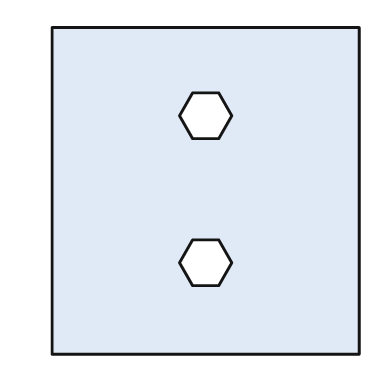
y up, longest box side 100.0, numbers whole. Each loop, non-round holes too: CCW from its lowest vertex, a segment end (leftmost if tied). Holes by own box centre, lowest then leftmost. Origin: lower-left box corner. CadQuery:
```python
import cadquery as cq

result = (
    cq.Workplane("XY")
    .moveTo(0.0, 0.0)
    .lineTo(94.0, 0.0)
    .lineTo(94.0, 100.0)
    .lineTo(0.0, 100.0)
    .close()
    .moveTo(43.0, 21.0)
    .lineTo(51.0, 21.0)
    .lineTo(55.0, 28.0)
    .lineTo(51.0, 35.0)
    .lineTo(43.0, 35.0)
    .lineTo(39.0, 28.0)
    .close()
    .moveTo(43.0, 66.0)
    .lineTo(51.0, 66.0)
    .lineTo(55.0, 73.0)
    .lineTo(51.0, 80.0)
    .lineTo(43.0, 80.0)
    .lineTo(39.0, 73.0)
    .close()
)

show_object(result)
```